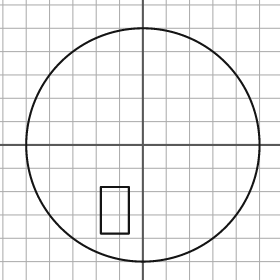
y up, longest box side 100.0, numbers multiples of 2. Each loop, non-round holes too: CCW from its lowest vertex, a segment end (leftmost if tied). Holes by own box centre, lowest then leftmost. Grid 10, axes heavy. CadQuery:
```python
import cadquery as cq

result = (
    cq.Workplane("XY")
    .moveTo(0.0, 0.0)
    .circle(50.0)
    .moveTo(-18.0, -38.0)
    .lineTo(-6.0, -38.0)
    .lineTo(-6.0, -18.0)
    .lineTo(-18.0, -18.0)
    .close()
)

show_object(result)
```